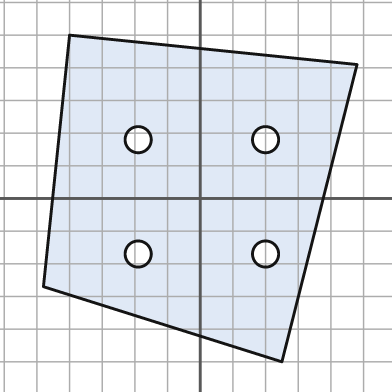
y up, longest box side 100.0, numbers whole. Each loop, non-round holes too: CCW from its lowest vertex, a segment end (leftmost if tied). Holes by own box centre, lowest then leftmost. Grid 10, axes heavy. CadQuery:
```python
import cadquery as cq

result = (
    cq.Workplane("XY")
    .moveTo(25.0, -50.0)
    .lineTo(48.0, 41.0)
    .lineTo(-40.0, 50.0)
    .lineTo(-48.0, -27.0)
    .close()
    .moveTo(-19.0, -17.0)
    .circle(4.0)
    .moveTo(20.0, -17.0)
    .circle(4.0)
    .moveTo(-19.0, 18.0)
    .circle(4.0)
    .moveTo(20.0, 18.0)
    .circle(4.0)
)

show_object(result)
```